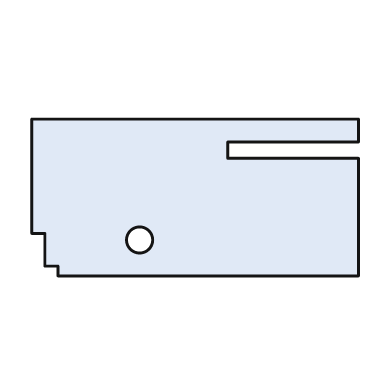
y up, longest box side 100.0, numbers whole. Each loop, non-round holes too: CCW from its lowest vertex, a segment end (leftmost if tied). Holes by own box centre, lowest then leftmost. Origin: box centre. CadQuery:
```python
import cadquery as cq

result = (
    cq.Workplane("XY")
    .moveTo(-42.0, -24.0)
    .lineTo(50.0, -24.0)
    .lineTo(50.0, 12.0)
    .lineTo(10.0, 12.0)
    .lineTo(10.0, 17.0)
    .lineTo(50.0, 17.0)
    .lineTo(50.0, 24.0)
    .lineTo(-50.0, 24.0)
    .lineTo(-50.0, -11.0)
    .lineTo(-46.0, -11.0)
    .lineTo(-46.0, -21.0)
    .lineTo(-42.0, -21.0)
    .close()
    .moveTo(-17.0, -13.0)
    .circle(4.0)
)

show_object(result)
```